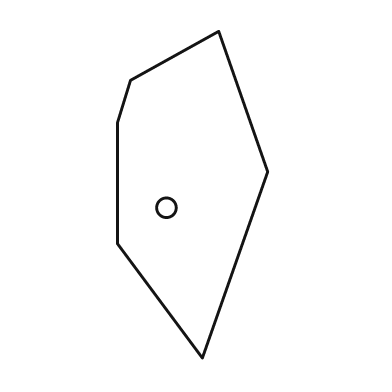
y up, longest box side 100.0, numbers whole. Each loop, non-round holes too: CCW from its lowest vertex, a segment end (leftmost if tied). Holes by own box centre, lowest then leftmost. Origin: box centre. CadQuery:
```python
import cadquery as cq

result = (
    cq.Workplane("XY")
    .moveTo(3.0, -50.0)
    .lineTo(23.0, 7.0)
    .lineTo(8.0, 50.0)
    .lineTo(-19.0, 35.0)
    .lineTo(-23.0, 22.0)
    .lineTo(-23.0, -15.0)
    .close()
    .moveTo(-8.0, -4.0)
    .circle(3.0)
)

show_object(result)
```